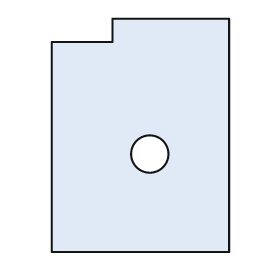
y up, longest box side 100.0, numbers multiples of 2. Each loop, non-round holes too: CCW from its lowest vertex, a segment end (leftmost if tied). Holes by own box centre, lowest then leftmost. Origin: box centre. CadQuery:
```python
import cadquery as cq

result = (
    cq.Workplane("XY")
    .moveTo(-38.0, -50.0)
    .lineTo(38.0, -50.0)
    .lineTo(38.0, 50.0)
    .lineTo(-12.0, 50.0)
    .lineTo(-12.0, 40.0)
    .lineTo(-38.0, 40.0)
    .close()
    .moveTo(4.0, -8.0)
    .circle(8.0)
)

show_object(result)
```